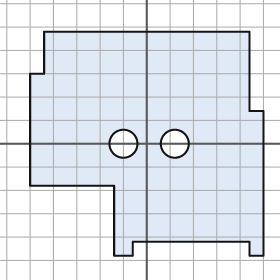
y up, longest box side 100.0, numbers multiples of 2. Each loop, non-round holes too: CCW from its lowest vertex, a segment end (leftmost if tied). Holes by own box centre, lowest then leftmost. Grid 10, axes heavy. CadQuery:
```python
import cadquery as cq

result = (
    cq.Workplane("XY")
    .moveTo(-14.0, -48.0)
    .lineTo(-6.0, -48.0)
    .lineTo(-6.0, -42.0)
    .lineTo(44.0, -42.0)
    .lineTo(44.0, -48.0)
    .lineTo(50.0, -48.0)
    .lineTo(50.0, 14.0)
    .lineTo(44.0, 14.0)
    .lineTo(44.0, 48.0)
    .lineTo(-44.0, 48.0)
    .lineTo(-44.0, 30.0)
    .lineTo(-50.0, 30.0)
    .lineTo(-50.0, -18.0)
    .lineTo(-14.0, -18.0)
    .close()
    .moveTo(-10.0, 0.0)
    .circle(6.0)
    .moveTo(12.0, 0.0)
    .circle(6.0)
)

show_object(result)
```